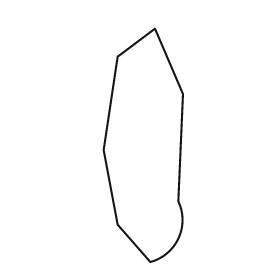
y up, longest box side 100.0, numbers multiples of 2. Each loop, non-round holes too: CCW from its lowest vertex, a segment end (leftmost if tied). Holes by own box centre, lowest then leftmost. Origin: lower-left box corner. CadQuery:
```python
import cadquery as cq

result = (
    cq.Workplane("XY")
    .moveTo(20.0, 0.0)
    .threePointArc((32.0, 10.0), (32.0, 26.0))
    .lineTo(34.0, 72.0)
    .lineTo(22.0, 100.0)
    .lineTo(6.0, 88.0)
    .lineTo(0.0, 48.0)
    .lineTo(6.0, 16.0)
    .close()
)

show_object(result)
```